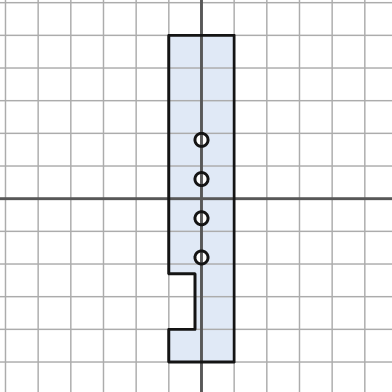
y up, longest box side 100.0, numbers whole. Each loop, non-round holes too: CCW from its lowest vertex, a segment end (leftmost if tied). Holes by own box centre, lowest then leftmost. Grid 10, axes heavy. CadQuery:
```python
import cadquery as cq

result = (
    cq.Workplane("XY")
    .moveTo(-10.0, -50.0)
    .lineTo(10.0, -50.0)
    .lineTo(10.0, 50.0)
    .lineTo(-10.0, 50.0)
    .lineTo(-10.0, -23.0)
    .lineTo(-2.0, -23.0)
    .lineTo(-2.0, -40.0)
    .lineTo(-10.0, -40.0)
    .close()
    .moveTo(0.0, -18.0)
    .circle(2.0)
    .moveTo(0.0, -6.0)
    .circle(2.0)
    .moveTo(0.0, 6.0)
    .circle(2.0)
    .moveTo(0.0, 18.0)
    .circle(2.0)
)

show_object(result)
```